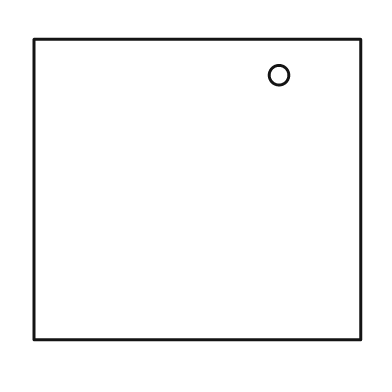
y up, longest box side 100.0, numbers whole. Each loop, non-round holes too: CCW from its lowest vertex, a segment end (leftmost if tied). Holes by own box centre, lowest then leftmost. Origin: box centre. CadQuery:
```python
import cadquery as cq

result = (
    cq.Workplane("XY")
    .moveTo(-50.0, -46.0)
    .lineTo(50.0, -46.0)
    .lineTo(50.0, 46.0)
    .lineTo(-50.0, 46.0)
    .close()
    .moveTo(25.0, 35.0)
    .circle(3.0)
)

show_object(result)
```